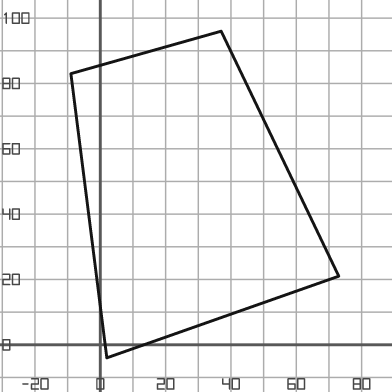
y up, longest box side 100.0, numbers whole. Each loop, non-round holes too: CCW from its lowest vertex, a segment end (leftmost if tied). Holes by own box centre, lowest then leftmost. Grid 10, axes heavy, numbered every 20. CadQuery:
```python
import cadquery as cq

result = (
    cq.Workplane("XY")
    .moveTo(2.0, -4.0)
    .lineTo(73.0, 21.0)
    .lineTo(37.0, 96.0)
    .lineTo(-9.0, 83.0)
    .close()
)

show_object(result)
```